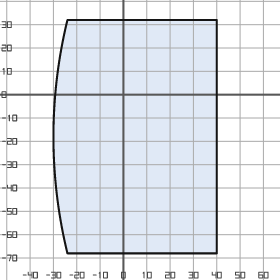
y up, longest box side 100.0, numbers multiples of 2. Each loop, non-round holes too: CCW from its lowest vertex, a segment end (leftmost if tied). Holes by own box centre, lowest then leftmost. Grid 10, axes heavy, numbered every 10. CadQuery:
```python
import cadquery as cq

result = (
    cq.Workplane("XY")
    .moveTo(-24.0, -68.0)
    .lineTo(40.0, -68.0)
    .lineTo(40.0, 32.0)
    .lineTo(-24.0, 32.0)
    .threePointArc((-30.0, -18.0), (-24.0, -68.0))
    .close()
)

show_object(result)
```